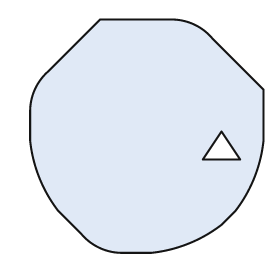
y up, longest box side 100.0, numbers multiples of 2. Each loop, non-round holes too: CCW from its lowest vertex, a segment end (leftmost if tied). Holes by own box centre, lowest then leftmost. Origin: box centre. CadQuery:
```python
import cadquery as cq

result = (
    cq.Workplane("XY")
    .moveTo(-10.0, -50.0)
    .lineTo(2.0, -50.0)
    .threePointArc((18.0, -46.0), (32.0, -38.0))
    .lineTo(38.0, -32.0)
    .threePointArc((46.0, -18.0), (50.0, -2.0))
    .lineTo(50.0, 20.0)
    .lineTo(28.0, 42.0)
    .threePointArc((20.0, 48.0), (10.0, 50.0))
    .lineTo(-20.0, 50.0)
    .lineTo(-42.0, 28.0)
    .threePointArc((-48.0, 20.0), (-50.0, 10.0))
    .lineTo(-50.0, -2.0)
    .threePointArc((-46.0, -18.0), (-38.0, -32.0))
    .lineTo(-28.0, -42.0)
    .threePointArc((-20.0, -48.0), (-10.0, -50.0))
    .close()
    .moveTo(24.0, -10.0)
    .lineTo(40.0, -10.0)
    .lineTo(32.0, 2.0)
    .close()
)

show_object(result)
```